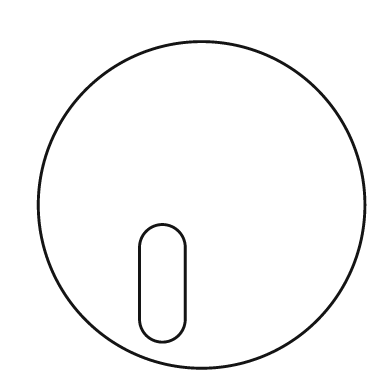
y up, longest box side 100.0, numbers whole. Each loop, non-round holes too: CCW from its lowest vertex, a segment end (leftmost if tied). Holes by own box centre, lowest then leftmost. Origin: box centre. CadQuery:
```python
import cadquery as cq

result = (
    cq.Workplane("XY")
    .moveTo(0.0, 0.0)
    .circle(50.0)
    .moveTo(-19.0, -35.0)
    .threePointArc((-12.0, -42.0), (-5.0, -35.0))
    .lineTo(-5.0, -13.0)
    .threePointArc((-12.0, -6.0), (-19.0, -13.0))
    .close()
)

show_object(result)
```